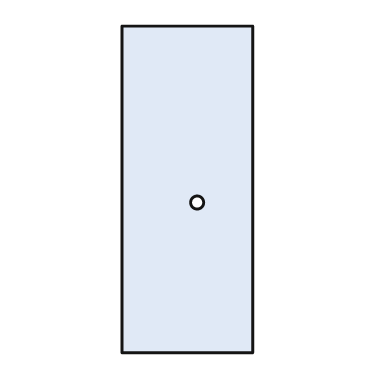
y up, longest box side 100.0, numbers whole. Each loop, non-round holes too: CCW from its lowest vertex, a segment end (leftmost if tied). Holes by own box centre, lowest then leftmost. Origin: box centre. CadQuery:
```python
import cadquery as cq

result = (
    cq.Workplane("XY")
    .moveTo(-20.0, -50.0)
    .lineTo(20.0, -50.0)
    .lineTo(20.0, 50.0)
    .lineTo(-20.0, 50.0)
    .close()
    .moveTo(3.0, -4.0)
    .circle(2.0)
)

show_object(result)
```